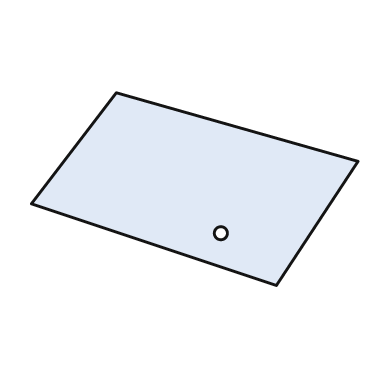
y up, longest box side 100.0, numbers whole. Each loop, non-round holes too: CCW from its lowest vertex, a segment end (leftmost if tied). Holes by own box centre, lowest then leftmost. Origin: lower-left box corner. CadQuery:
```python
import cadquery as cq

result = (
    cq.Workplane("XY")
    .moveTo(75.0, 0.0)
    .lineTo(100.0, 38.0)
    .lineTo(26.0, 59.0)
    .lineTo(0.0, 25.0)
    .close()
    .moveTo(58.0, 16.0)
    .circle(2.0)
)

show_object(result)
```